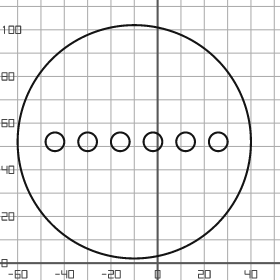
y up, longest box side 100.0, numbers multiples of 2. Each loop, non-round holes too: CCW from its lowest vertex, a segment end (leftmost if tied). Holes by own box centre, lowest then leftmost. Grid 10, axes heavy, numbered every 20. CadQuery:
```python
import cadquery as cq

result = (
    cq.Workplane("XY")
    .moveTo(-10.0, 52.0)
    .circle(50.0)
    .moveTo(-44.0, 52.0)
    .circle(4.0)
    .moveTo(-30.0, 52.0)
    .circle(4.0)
    .moveTo(-16.0, 52.0)
    .circle(4.0)
    .moveTo(-2.0, 52.0)
    .circle(4.0)
    .moveTo(12.0, 52.0)
    .circle(4.0)
    .moveTo(26.0, 52.0)
    .circle(4.0)
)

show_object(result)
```